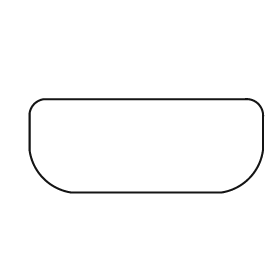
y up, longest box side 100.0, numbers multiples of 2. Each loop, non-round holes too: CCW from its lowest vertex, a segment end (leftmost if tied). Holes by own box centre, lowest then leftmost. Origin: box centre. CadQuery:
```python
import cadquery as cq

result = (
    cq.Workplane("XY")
    .moveTo(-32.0, -20.0)
    .lineTo(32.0, -20.0)
    .threePointArc((44.0, -14.0), (50.0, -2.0))
    .lineTo(50.0, 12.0)
    .threePointArc((48.0, 18.0), (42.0, 20.0))
    .lineTo(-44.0, 20.0)
    .threePointArc((-48.0, 18.0), (-50.0, 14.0))
    .lineTo(-50.0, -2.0)
    .threePointArc((-44.0, -14.0), (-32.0, -20.0))
    .close()
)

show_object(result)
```